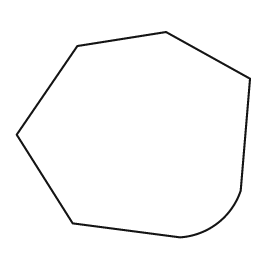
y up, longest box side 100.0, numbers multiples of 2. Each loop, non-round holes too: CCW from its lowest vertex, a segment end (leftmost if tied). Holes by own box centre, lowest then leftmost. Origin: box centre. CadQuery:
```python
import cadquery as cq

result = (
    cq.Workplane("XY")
    .moveTo(20.0, -44.0)
    .threePointArc((36.0, -38.0), (46.0, -24.0))
    .lineTo(50.0, 24.0)
    .lineTo(14.0, 44.0)
    .lineTo(-24.0, 38.0)
    .lineTo(-50.0, 0.0)
    .lineTo(-26.0, -38.0)
    .close()
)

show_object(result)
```